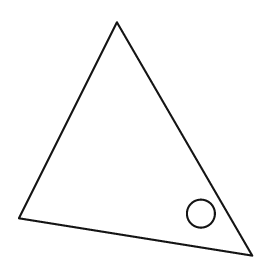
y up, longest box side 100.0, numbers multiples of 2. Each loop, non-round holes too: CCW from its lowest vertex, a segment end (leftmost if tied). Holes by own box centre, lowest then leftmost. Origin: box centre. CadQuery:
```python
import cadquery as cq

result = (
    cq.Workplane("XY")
    .moveTo(50.0, -50.0)
    .lineTo(-8.0, 50.0)
    .lineTo(-50.0, -34.0)
    .close()
    .moveTo(28.0, -32.0)
    .circle(6.0)
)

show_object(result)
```